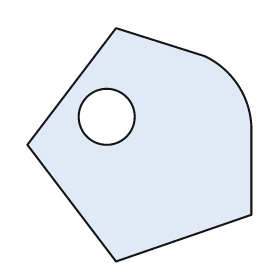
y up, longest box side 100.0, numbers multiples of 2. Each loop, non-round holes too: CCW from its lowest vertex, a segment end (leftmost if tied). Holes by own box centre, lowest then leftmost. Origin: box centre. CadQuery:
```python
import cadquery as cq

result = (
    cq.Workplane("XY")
    .moveTo(-10.0, -50.0)
    .lineTo(48.0, -30.0)
    .lineTo(48.0, 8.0)
    .threePointArc((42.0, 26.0), (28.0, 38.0))
    .lineTo(-10.0, 50.0)
    .lineTo(-48.0, 0.0)
    .close()
    .moveTo(-14.0, 12.0)
    .circle(12.0)
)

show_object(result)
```